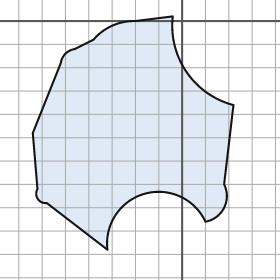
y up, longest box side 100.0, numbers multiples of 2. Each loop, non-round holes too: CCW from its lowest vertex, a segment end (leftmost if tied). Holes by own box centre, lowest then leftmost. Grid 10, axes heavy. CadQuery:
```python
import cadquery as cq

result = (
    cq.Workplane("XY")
    .moveTo(-32.0, -98.0)
    .threePointArc((-16.0, -74.0), (10.0, -86.0))
    .threePointArc((18.0, -80.0), (18.0, -70.0))
    .lineTo(22.0, -36.0)
    .threePointArc((2.0, -22.0), (-4.0, 2.0))
    .lineTo(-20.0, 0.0)
    .threePointArc((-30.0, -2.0), (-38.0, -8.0))
    .lineTo(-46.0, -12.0)
    .threePointArc((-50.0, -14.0), (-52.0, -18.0))
    .lineTo(-64.0, -48.0)
    .lineTo(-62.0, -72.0)
    .threePointArc((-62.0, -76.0), (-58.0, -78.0))
    .close()
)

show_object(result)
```